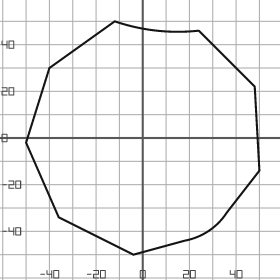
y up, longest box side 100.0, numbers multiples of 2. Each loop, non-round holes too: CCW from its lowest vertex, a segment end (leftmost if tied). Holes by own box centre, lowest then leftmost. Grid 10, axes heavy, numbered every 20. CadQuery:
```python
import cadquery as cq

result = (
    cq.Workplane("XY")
    .moveTo(-4.0, -50.0)
    .lineTo(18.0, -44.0)
    .threePointArc((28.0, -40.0), (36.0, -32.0))
    .lineTo(50.0, -14.0)
    .lineTo(48.0, 22.0)
    .lineTo(24.0, 46.0)
    .threePointArc((6.0, 46.0), (-12.0, 50.0))
    .lineTo(-40.0, 30.0)
    .lineTo(-50.0, -2.0)
    .lineTo(-36.0, -34.0)
    .close()
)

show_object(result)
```